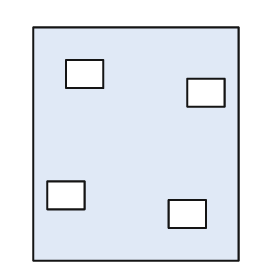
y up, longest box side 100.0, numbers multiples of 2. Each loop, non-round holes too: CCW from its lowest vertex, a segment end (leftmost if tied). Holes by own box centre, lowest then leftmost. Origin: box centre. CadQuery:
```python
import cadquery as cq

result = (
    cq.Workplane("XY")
    .moveTo(-44.0, -50.0)
    .lineTo(44.0, -50.0)
    .lineTo(44.0, 50.0)
    .lineTo(-44.0, 50.0)
    .close()
    .moveTo(14.0, -36.0)
    .lineTo(30.0, -36.0)
    .lineTo(30.0, -24.0)
    .lineTo(14.0, -24.0)
    .close()
    .moveTo(-38.0, -28.0)
    .lineTo(-22.0, -28.0)
    .lineTo(-22.0, -16.0)
    .lineTo(-38.0, -16.0)
    .close()
    .moveTo(22.0, 16.0)
    .lineTo(38.0, 16.0)
    .lineTo(38.0, 28.0)
    .lineTo(22.0, 28.0)
    .close()
    .moveTo(-30.0, 24.0)
    .lineTo(-14.0, 24.0)
    .lineTo(-14.0, 36.0)
    .lineTo(-30.0, 36.0)
    .close()
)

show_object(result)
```